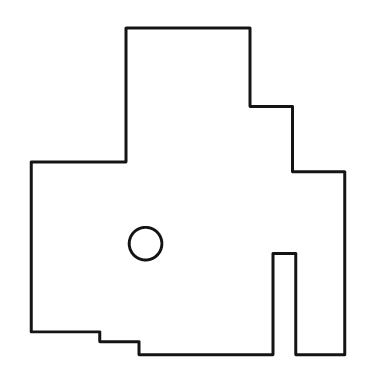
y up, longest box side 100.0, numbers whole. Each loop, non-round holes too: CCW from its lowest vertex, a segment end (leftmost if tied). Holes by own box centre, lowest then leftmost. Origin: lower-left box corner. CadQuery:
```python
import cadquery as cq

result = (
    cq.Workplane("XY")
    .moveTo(33.0, 0.0)
    .lineTo(74.0, 0.0)
    .lineTo(74.0, 31.0)
    .lineTo(81.0, 31.0)
    .lineTo(81.0, 0.0)
    .lineTo(96.0, 0.0)
    .lineTo(96.0, 56.0)
    .lineTo(80.0, 56.0)
    .lineTo(80.0, 76.0)
    .lineTo(67.0, 76.0)
    .lineTo(67.0, 100.0)
    .lineTo(29.0, 100.0)
    .lineTo(29.0, 59.0)
    .lineTo(0.0, 59.0)
    .lineTo(0.0, 7.0)
    .lineTo(21.0, 7.0)
    .lineTo(21.0, 4.0)
    .lineTo(33.0, 4.0)
    .close()
    .moveTo(35.0, 34.0)
    .circle(5.0)
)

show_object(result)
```